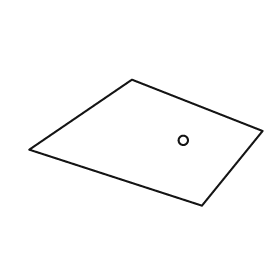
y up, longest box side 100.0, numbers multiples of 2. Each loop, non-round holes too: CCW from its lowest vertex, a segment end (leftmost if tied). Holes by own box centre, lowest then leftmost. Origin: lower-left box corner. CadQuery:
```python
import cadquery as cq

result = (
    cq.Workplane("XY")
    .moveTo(74.0, 0.0)
    .lineTo(100.0, 32.0)
    .lineTo(44.0, 54.0)
    .lineTo(0.0, 24.0)
    .close()
    .moveTo(66.0, 28.0)
    .circle(2.0)
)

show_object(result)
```